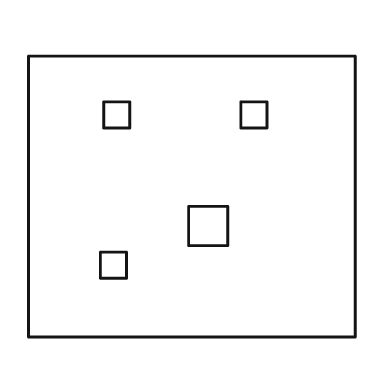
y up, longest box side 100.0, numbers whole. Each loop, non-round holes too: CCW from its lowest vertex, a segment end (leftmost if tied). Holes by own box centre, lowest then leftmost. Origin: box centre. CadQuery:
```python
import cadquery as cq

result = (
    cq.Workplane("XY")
    .moveTo(-50.0, -43.0)
    .lineTo(50.0, -43.0)
    .lineTo(50.0, 43.0)
    .lineTo(-50.0, 43.0)
    .close()
    .moveTo(-28.0, -25.0)
    .lineTo(-20.0, -25.0)
    .lineTo(-20.0, -17.0)
    .lineTo(-28.0, -17.0)
    .close()
    .moveTo(-1.0, -15.0)
    .lineTo(11.0, -15.0)
    .lineTo(11.0, -3.0)
    .lineTo(-1.0, -3.0)
    .close()
    .moveTo(-27.0, 21.0)
    .lineTo(-19.0, 21.0)
    .lineTo(-19.0, 29.0)
    .lineTo(-27.0, 29.0)
    .close()
    .moveTo(15.0, 21.0)
    .lineTo(23.0, 21.0)
    .lineTo(23.0, 29.0)
    .lineTo(15.0, 29.0)
    .close()
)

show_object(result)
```